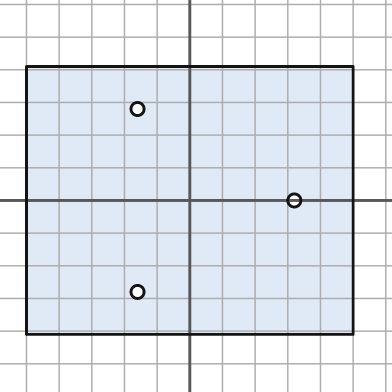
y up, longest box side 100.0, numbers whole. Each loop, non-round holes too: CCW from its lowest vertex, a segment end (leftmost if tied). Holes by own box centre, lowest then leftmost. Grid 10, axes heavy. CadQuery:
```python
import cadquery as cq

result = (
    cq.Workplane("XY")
    .moveTo(-50.0, -41.0)
    .lineTo(50.0, -41.0)
    .lineTo(50.0, 41.0)
    .lineTo(-50.0, 41.0)
    .close()
    .moveTo(-16.0, -28.0)
    .circle(2.0)
    .moveTo(32.0, 0.0)
    .circle(2.0)
    .moveTo(-16.0, 28.0)
    .circle(2.0)
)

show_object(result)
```